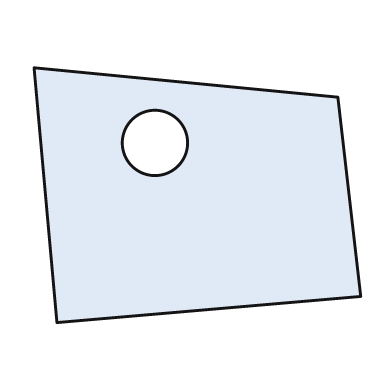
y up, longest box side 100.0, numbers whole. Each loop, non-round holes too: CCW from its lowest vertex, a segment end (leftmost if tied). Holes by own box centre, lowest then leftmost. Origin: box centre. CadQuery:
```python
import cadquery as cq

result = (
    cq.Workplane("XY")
    .moveTo(-43.0, -39.0)
    .lineTo(50.0, -31.0)
    .lineTo(43.0, 30.0)
    .lineTo(-50.0, 39.0)
    .close()
    .moveTo(-13.0, 16.0)
    .circle(10.0)
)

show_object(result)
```